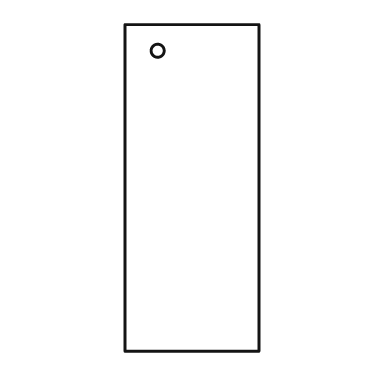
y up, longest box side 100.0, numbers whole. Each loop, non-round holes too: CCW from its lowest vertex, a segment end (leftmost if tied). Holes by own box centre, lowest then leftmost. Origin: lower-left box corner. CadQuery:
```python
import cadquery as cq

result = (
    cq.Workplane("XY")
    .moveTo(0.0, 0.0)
    .lineTo(41.0, 0.0)
    .lineTo(41.0, 100.0)
    .lineTo(0.0, 100.0)
    .close()
    .moveTo(10.0, 92.0)
    .circle(2.0)
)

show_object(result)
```